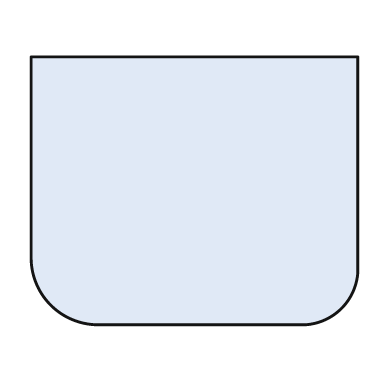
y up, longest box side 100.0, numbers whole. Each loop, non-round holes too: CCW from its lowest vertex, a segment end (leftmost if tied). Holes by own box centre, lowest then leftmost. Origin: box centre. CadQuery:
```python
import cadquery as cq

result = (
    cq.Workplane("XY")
    .moveTo(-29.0, -41.0)
    .lineTo(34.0, -41.0)
    .threePointArc((45.0, -36.0), (50.0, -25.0))
    .lineTo(50.0, 41.0)
    .lineTo(-50.0, 41.0)
    .lineTo(-50.0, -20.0)
    .threePointArc((-44.0, -35.0), (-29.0, -41.0))
    .close()
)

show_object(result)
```